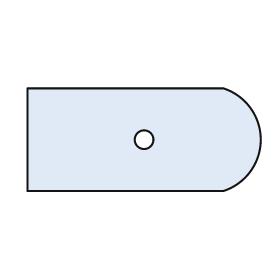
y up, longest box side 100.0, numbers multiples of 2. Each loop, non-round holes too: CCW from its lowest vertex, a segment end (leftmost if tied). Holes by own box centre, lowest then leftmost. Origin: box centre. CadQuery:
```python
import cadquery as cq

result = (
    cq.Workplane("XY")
    .moveTo(-50.0, -22.0)
    .lineTo(34.0, -22.0)
    .threePointArc((50.0, 0.0), (34.0, 22.0))
    .lineTo(-50.0, 22.0)
    .close()
    .moveTo(0.0, 0.0)
    .circle(4.0)
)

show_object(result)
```